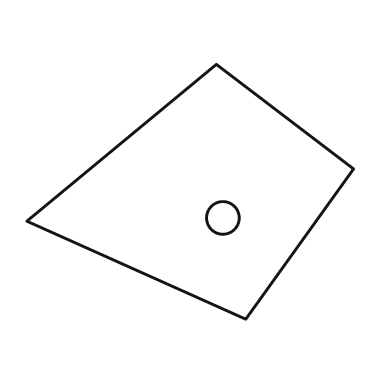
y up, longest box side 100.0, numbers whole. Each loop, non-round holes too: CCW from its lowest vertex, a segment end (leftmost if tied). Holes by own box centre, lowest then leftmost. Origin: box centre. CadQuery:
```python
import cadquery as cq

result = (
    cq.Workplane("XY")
    .moveTo(17.0, -39.0)
    .lineTo(50.0, 7.0)
    .lineTo(8.0, 39.0)
    .lineTo(-50.0, -9.0)
    .close()
    .moveTo(10.0, -8.0)
    .circle(5.0)
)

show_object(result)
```